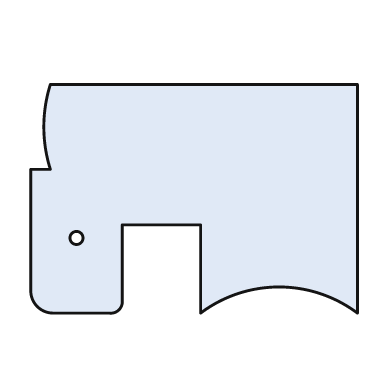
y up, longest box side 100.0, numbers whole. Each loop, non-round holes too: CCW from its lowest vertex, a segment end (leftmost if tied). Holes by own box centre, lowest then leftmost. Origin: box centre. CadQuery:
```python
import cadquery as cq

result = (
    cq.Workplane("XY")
    .moveTo(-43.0, -35.0)
    .lineTo(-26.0, -35.0)
    .threePointArc((-23.0, -34.0), (-22.0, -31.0))
    .lineTo(-22.0, -8.0)
    .lineTo(2.0, -8.0)
    .lineTo(2.0, -35.0)
    .threePointArc((26.0, -27.0), (50.0, -35.0))
    .lineTo(50.0, 35.0)
    .lineTo(-44.0, 35.0)
    .threePointArc((-46.0, 22.0), (-44.0, 9.0))
    .lineTo(-50.0, 9.0)
    .lineTo(-50.0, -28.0)
    .threePointArc((-48.0, -33.0), (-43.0, -35.0))
    .close()
    .moveTo(-36.0, -12.0)
    .circle(2.0)
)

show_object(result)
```